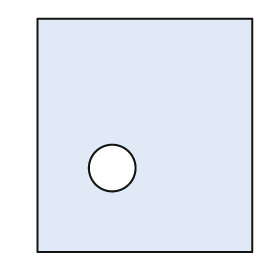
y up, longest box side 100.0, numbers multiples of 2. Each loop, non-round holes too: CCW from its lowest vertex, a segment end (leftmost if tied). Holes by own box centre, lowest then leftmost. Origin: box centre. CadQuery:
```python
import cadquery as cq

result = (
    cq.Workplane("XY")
    .moveTo(-46.0, -50.0)
    .lineTo(46.0, -50.0)
    .lineTo(46.0, 50.0)
    .lineTo(-46.0, 50.0)
    .close()
    .moveTo(-14.0, -14.0)
    .circle(10.0)
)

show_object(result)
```